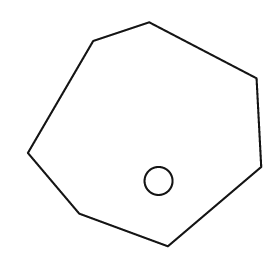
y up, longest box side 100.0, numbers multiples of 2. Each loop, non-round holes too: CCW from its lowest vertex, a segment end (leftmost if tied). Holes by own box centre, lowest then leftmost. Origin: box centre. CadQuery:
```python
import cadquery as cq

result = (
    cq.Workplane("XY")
    .moveTo(10.0, -48.0)
    .lineTo(50.0, -14.0)
    .lineTo(48.0, 24.0)
    .lineTo(2.0, 48.0)
    .lineTo(-22.0, 40.0)
    .lineTo(-50.0, -8.0)
    .lineTo(-28.0, -34.0)
    .close()
    .moveTo(6.0, -20.0)
    .circle(6.0)
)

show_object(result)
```